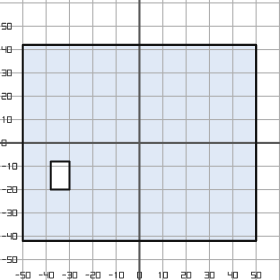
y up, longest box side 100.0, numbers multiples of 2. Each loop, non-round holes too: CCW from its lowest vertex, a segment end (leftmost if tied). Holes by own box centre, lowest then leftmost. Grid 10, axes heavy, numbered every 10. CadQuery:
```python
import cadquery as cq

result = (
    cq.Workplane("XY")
    .moveTo(-50.0, -42.0)
    .lineTo(50.0, -42.0)
    .lineTo(50.0, 42.0)
    .lineTo(-50.0, 42.0)
    .close()
    .moveTo(-38.0, -20.0)
    .lineTo(-30.0, -20.0)
    .lineTo(-30.0, -8.0)
    .lineTo(-38.0, -8.0)
    .close()
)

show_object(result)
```